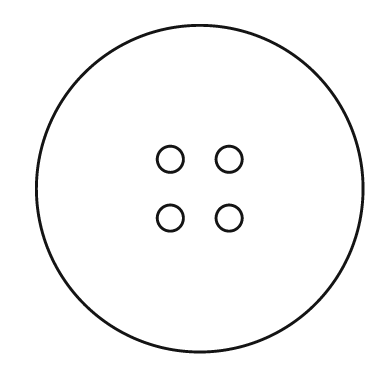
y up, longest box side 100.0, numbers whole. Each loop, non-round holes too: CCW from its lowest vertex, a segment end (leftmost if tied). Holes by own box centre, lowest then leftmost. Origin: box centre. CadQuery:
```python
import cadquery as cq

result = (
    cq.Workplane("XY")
    .moveTo(0.0, 0.0)
    .circle(50.0)
    .moveTo(-9.0, -9.0)
    .circle(4.0)
    .moveTo(9.0, -9.0)
    .circle(4.0)
    .moveTo(-9.0, 9.0)
    .circle(4.0)
    .moveTo(9.0, 9.0)
    .circle(4.0)
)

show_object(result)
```